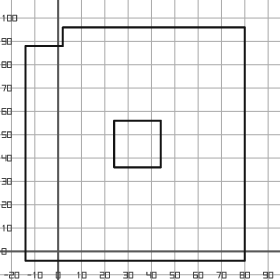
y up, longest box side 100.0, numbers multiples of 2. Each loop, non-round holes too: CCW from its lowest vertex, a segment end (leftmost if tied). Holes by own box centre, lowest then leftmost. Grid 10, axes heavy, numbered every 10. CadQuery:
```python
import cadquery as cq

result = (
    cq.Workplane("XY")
    .moveTo(-14.0, -4.0)
    .lineTo(80.0, -4.0)
    .lineTo(80.0, 96.0)
    .lineTo(2.0, 96.0)
    .lineTo(2.0, 88.0)
    .lineTo(-14.0, 88.0)
    .close()
    .moveTo(24.0, 36.0)
    .lineTo(44.0, 36.0)
    .lineTo(44.0, 56.0)
    .lineTo(24.0, 56.0)
    .close()
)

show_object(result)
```